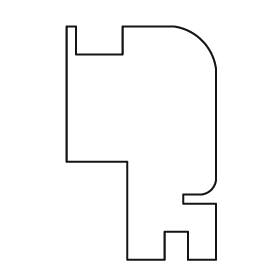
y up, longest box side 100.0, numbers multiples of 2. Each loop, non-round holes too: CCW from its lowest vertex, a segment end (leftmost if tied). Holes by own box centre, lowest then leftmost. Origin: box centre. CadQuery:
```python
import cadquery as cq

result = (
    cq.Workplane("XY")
    .moveTo(-6.0, -50.0)
    .lineTo(10.0, -50.0)
    .lineTo(10.0, -38.0)
    .lineTo(20.0, -38.0)
    .lineTo(20.0, -50.0)
    .lineTo(32.0, -50.0)
    .lineTo(32.0, -26.0)
    .lineTo(18.0, -26.0)
    .lineTo(18.0, -22.0)
    .lineTo(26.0, -22.0)
    .threePointArc((30.0, -20.0), (32.0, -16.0))
    .lineTo(32.0, 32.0)
    .threePointArc((26.0, 44.0), (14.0, 50.0))
    .lineTo(-8.0, 50.0)
    .lineTo(-8.0, 38.0)
    .lineTo(-28.0, 38.0)
    .lineTo(-28.0, 50.0)
    .lineTo(-32.0, 50.0)
    .lineTo(-32.0, -8.0)
    .lineTo(-6.0, -8.0)
    .close()
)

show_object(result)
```